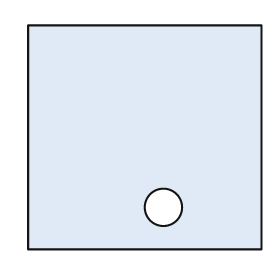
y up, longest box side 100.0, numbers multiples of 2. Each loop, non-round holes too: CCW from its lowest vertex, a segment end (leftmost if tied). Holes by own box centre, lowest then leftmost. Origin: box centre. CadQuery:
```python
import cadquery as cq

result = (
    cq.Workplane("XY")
    .moveTo(-50.0, -48.0)
    .lineTo(50.0, -48.0)
    .lineTo(50.0, 48.0)
    .lineTo(-50.0, 48.0)
    .close()
    .moveTo(8.0, -30.0)
    .circle(8.0)
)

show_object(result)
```